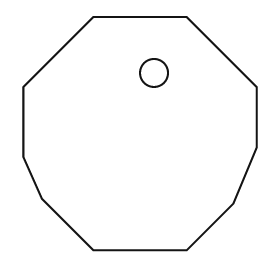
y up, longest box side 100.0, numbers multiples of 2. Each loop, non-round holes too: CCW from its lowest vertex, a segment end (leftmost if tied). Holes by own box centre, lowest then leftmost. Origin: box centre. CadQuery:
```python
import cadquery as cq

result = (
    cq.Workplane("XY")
    .moveTo(-20.0, -50.0)
    .lineTo(20.0, -50.0)
    .lineTo(40.0, -30.0)
    .lineTo(50.0, -6.0)
    .lineTo(50.0, 20.0)
    .lineTo(20.0, 50.0)
    .lineTo(-20.0, 50.0)
    .lineTo(-50.0, 20.0)
    .lineTo(-50.0, -10.0)
    .lineTo(-42.0, -28.0)
    .close()
    .moveTo(6.0, 26.0)
    .circle(6.0)
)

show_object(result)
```